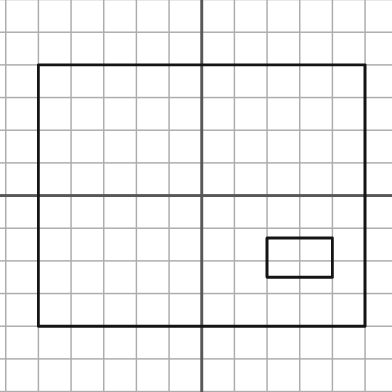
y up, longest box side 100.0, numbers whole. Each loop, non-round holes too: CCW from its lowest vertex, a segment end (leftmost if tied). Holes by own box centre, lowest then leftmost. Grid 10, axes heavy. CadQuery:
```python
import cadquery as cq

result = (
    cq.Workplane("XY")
    .moveTo(-50.0, -40.0)
    .lineTo(50.0, -40.0)
    .lineTo(50.0, 40.0)
    .lineTo(-50.0, 40.0)
    .close()
    .moveTo(20.0, -25.0)
    .lineTo(40.0, -25.0)
    .lineTo(40.0, -13.0)
    .lineTo(20.0, -13.0)
    .close()
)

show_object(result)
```